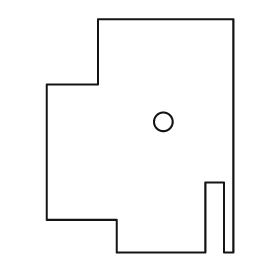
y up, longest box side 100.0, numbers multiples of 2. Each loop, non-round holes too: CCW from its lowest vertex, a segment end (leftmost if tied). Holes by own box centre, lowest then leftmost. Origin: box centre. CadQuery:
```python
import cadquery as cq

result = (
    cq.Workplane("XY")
    .moveTo(-10.0, -50.0)
    .lineTo(28.0, -50.0)
    .lineTo(28.0, -20.0)
    .lineTo(36.0, -20.0)
    .lineTo(36.0, -50.0)
    .lineTo(40.0, -50.0)
    .lineTo(40.0, 50.0)
    .lineTo(-18.0, 50.0)
    .lineTo(-18.0, 22.0)
    .lineTo(-40.0, 22.0)
    .lineTo(-40.0, -36.0)
    .lineTo(-10.0, -36.0)
    .close()
    .moveTo(10.0, 6.0)
    .circle(4.0)
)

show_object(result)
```